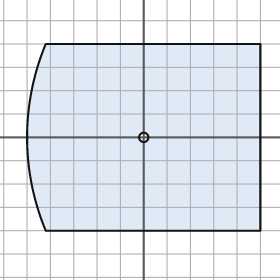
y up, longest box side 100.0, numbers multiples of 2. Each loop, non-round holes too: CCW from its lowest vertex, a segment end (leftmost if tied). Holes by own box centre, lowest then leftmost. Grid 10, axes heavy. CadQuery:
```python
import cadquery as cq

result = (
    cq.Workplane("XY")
    .moveTo(-42.0, -40.0)
    .lineTo(50.0, -40.0)
    .lineTo(50.0, 40.0)
    .lineTo(-42.0, 40.0)
    .threePointArc((-50.0, 0.0), (-42.0, -40.0))
    .close()
    .moveTo(0.0, 0.0)
    .circle(2.0)
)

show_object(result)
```